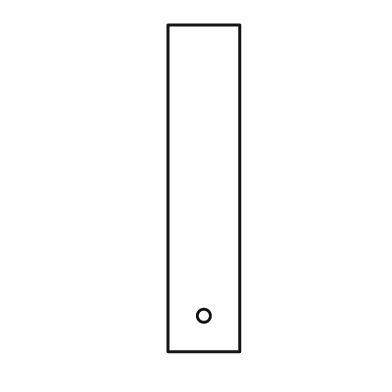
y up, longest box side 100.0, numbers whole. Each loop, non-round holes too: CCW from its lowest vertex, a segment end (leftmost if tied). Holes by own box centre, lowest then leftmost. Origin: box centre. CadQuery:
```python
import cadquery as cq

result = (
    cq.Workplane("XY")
    .moveTo(-11.0, -50.0)
    .lineTo(11.0, -50.0)
    .lineTo(11.0, 50.0)
    .lineTo(-11.0, 50.0)
    .close()
    .moveTo(0.0, -39.0)
    .circle(2.0)
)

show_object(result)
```